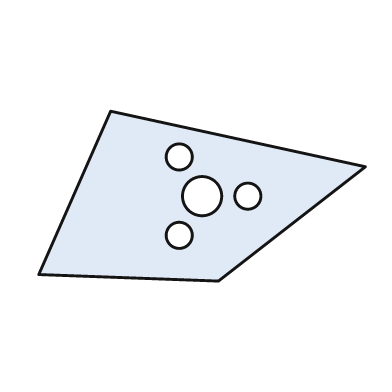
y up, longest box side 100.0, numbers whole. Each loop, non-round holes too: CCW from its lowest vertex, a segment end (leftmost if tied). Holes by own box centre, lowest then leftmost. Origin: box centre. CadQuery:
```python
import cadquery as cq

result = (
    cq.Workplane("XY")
    .moveTo(5.0, -26.0)
    .lineTo(50.0, 9.0)
    .lineTo(-28.0, 26.0)
    .lineTo(-50.0, -24.0)
    .close()
    .moveTo(-7.0, -12.0)
    .circle(4.0)
    .moveTo(0.0, 0.0)
    .circle(6.0)
    .moveTo(14.0, 0.0)
    .circle(4.0)
    .moveTo(-7.0, 12.0)
    .circle(4.0)
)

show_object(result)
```